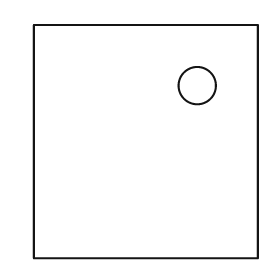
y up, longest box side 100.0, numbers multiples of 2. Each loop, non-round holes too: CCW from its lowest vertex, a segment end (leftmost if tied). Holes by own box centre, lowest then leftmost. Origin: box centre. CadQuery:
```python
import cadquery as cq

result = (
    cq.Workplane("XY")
    .moveTo(-48.0, -50.0)
    .lineTo(48.0, -50.0)
    .lineTo(48.0, 50.0)
    .lineTo(-48.0, 50.0)
    .close()
    .moveTo(22.0, 24.0)
    .circle(8.0)
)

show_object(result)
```